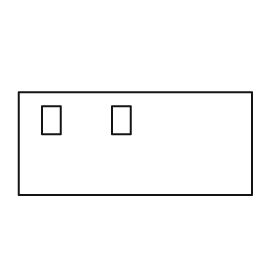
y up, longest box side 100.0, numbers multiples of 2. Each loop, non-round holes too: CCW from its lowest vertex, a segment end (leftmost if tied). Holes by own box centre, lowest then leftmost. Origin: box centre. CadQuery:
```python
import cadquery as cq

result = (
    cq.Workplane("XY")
    .moveTo(-50.0, -22.0)
    .lineTo(50.0, -22.0)
    .lineTo(50.0, 22.0)
    .lineTo(-50.0, 22.0)
    .close()
    .moveTo(-40.0, 4.0)
    .lineTo(-32.0, 4.0)
    .lineTo(-32.0, 16.0)
    .lineTo(-40.0, 16.0)
    .close()
    .moveTo(-10.0, 4.0)
    .lineTo(-2.0, 4.0)
    .lineTo(-2.0, 16.0)
    .lineTo(-10.0, 16.0)
    .close()
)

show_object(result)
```